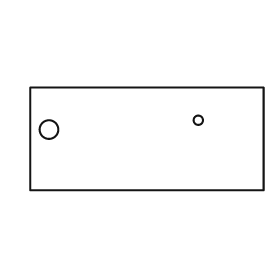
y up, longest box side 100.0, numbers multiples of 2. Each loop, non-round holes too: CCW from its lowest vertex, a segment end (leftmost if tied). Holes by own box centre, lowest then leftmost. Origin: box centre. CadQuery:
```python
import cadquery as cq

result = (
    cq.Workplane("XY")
    .moveTo(-50.0, -22.0)
    .lineTo(50.0, -22.0)
    .lineTo(50.0, 22.0)
    .lineTo(-50.0, 22.0)
    .close()
    .moveTo(-42.0, 4.0)
    .circle(4.0)
    .moveTo(22.0, 8.0)
    .circle(2.0)
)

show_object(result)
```